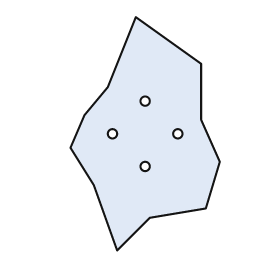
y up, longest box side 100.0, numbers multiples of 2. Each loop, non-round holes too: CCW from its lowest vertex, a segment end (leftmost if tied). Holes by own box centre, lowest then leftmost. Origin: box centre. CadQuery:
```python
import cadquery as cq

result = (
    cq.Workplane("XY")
    .moveTo(-12.0, -50.0)
    .lineTo(2.0, -36.0)
    .lineTo(26.0, -32.0)
    .lineTo(32.0, -12.0)
    .lineTo(24.0, 6.0)
    .lineTo(24.0, 30.0)
    .lineTo(-4.0, 50.0)
    .lineTo(-16.0, 20.0)
    .lineTo(-26.0, 8.0)
    .lineTo(-32.0, -6.0)
    .lineTo(-22.0, -22.0)
    .close()
    .moveTo(0.0, -14.0)
    .circle(2.0)
    .moveTo(-14.0, 0.0)
    .circle(2.0)
    .moveTo(14.0, 0.0)
    .circle(2.0)
    .moveTo(0.0, 14.0)
    .circle(2.0)
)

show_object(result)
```